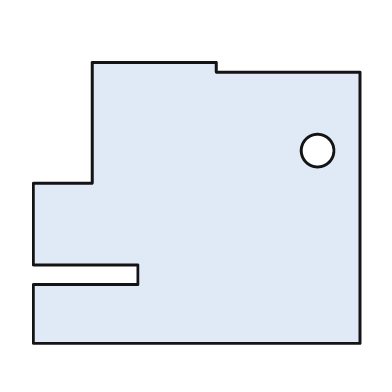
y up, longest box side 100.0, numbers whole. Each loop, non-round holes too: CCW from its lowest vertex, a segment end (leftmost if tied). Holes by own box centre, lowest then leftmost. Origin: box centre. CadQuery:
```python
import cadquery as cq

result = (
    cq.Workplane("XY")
    .moveTo(-50.0, -43.0)
    .lineTo(50.0, -43.0)
    .lineTo(50.0, 40.0)
    .lineTo(6.0, 40.0)
    .lineTo(6.0, 43.0)
    .lineTo(-32.0, 43.0)
    .lineTo(-32.0, 6.0)
    .lineTo(-50.0, 6.0)
    .lineTo(-50.0, -19.0)
    .lineTo(-18.0, -19.0)
    .lineTo(-18.0, -25.0)
    .lineTo(-50.0, -25.0)
    .close()
    .moveTo(37.0, 16.0)
    .circle(5.0)
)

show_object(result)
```